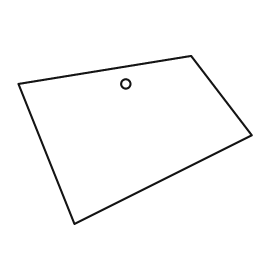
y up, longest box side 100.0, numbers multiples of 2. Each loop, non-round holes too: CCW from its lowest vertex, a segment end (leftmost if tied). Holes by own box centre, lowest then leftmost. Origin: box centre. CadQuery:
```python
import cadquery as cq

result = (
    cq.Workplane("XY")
    .moveTo(-26.0, -36.0)
    .lineTo(50.0, 2.0)
    .lineTo(24.0, 36.0)
    .lineTo(-50.0, 24.0)
    .close()
    .moveTo(-4.0, 24.0)
    .circle(2.0)
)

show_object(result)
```